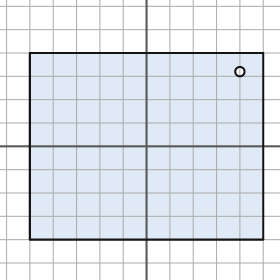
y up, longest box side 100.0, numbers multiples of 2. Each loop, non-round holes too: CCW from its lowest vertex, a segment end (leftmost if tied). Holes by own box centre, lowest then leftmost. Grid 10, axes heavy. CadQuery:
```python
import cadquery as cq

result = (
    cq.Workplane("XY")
    .moveTo(-50.0, -40.0)
    .lineTo(50.0, -40.0)
    .lineTo(50.0, 40.0)
    .lineTo(-50.0, 40.0)
    .close()
    .moveTo(40.0, 32.0)
    .circle(2.0)
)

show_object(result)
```